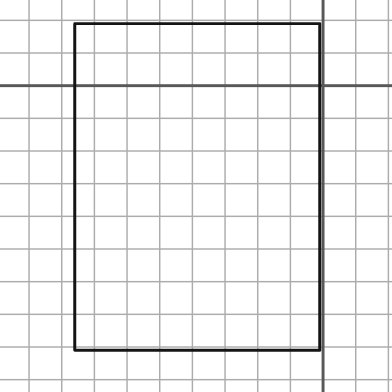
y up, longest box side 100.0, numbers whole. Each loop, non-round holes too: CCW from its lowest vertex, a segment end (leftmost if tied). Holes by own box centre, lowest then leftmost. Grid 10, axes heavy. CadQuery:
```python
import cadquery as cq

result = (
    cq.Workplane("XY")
    .moveTo(-76.0, -81.0)
    .lineTo(-1.0, -81.0)
    .lineTo(-1.0, 19.0)
    .lineTo(-76.0, 19.0)
    .close()
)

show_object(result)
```